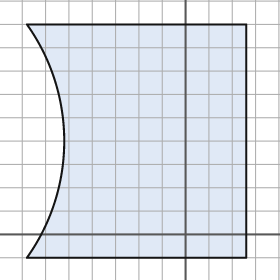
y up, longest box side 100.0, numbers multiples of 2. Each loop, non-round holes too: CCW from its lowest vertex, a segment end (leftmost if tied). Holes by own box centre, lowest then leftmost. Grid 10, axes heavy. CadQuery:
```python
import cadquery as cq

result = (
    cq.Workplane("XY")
    .moveTo(-68.0, -10.0)
    .lineTo(26.0, -10.0)
    .lineTo(26.0, 90.0)
    .lineTo(-68.0, 90.0)
    .threePointArc((-52.0, 40.0), (-68.0, -10.0))
    .close()
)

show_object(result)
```